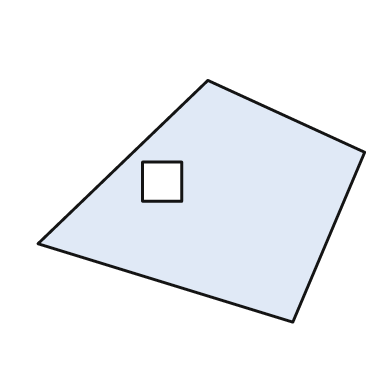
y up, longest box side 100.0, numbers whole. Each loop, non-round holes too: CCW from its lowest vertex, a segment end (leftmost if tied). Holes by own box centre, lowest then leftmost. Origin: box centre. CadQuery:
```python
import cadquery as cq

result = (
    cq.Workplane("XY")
    .moveTo(28.0, -37.0)
    .lineTo(50.0, 15.0)
    .lineTo(2.0, 37.0)
    .lineTo(-50.0, -13.0)
    .close()
    .moveTo(-18.0, 0.0)
    .lineTo(-6.0, 0.0)
    .lineTo(-6.0, 12.0)
    .lineTo(-18.0, 12.0)
    .close()
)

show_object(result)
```